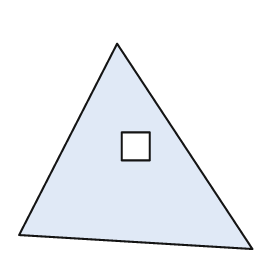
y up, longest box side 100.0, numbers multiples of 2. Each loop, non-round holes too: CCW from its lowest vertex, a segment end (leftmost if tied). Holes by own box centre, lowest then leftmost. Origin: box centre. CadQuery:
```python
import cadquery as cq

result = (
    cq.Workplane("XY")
    .moveTo(50.0, -44.0)
    .lineTo(-8.0, 44.0)
    .lineTo(-50.0, -38.0)
    .close()
    .moveTo(-6.0, -6.0)
    .lineTo(6.0, -6.0)
    .lineTo(6.0, 6.0)
    .lineTo(-6.0, 6.0)
    .close()
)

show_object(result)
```